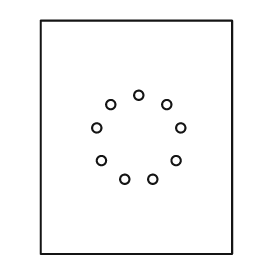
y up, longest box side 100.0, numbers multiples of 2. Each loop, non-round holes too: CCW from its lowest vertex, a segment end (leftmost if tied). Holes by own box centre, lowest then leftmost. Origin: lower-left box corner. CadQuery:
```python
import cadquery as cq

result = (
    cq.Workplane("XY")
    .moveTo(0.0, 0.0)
    .lineTo(82.0, 0.0)
    .lineTo(82.0, 100.0)
    .lineTo(0.0, 100.0)
    .close()
    .moveTo(36.0, 32.0)
    .circle(2.0)
    .moveTo(48.0, 32.0)
    .circle(2.0)
    .moveTo(26.0, 40.0)
    .circle(2.0)
    .moveTo(58.0, 40.0)
    .circle(2.0)
    .moveTo(24.0, 54.0)
    .circle(2.0)
    .moveTo(60.0, 54.0)
    .circle(2.0)
    .moveTo(30.0, 64.0)
    .circle(2.0)
    .moveTo(54.0, 64.0)
    .circle(2.0)
    .moveTo(42.0, 68.0)
    .circle(2.0)
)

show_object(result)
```